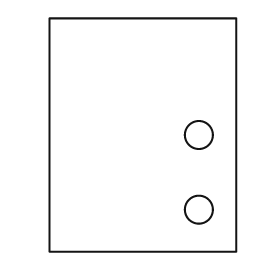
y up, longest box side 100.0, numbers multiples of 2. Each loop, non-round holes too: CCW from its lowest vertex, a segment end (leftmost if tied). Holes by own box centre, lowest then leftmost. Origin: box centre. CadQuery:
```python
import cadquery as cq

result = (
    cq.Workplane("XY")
    .moveTo(-40.0, -50.0)
    .lineTo(40.0, -50.0)
    .lineTo(40.0, 50.0)
    .lineTo(-40.0, 50.0)
    .close()
    .moveTo(24.0, -32.0)
    .circle(6.0)
    .moveTo(24.0, 0.0)
    .circle(6.0)
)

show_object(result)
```